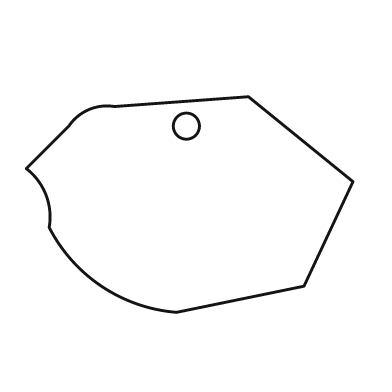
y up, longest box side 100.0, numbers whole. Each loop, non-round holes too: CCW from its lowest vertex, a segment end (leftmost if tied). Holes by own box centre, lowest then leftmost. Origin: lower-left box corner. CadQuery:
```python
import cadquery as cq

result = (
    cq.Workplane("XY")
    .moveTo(46.0, 0.0)
    .lineTo(85.0, 8.0)
    .lineTo(100.0, 40.0)
    .lineTo(68.0, 66.0)
    .lineTo(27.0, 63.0)
    .threePointArc((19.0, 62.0), (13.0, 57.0))
    .lineTo(0.0, 44.0)
    .threePointArc((6.0, 36.0), (7.0, 26.0))
    .threePointArc((23.0, 8.0), (46.0, 0.0))
    .close()
    .moveTo(49.0, 57.0)
    .circle(4.0)
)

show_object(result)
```